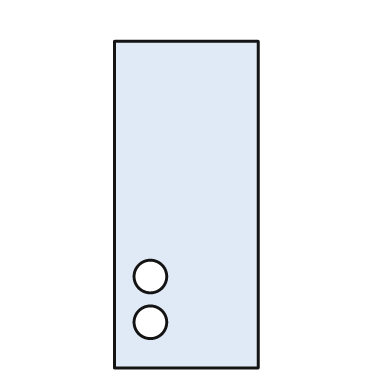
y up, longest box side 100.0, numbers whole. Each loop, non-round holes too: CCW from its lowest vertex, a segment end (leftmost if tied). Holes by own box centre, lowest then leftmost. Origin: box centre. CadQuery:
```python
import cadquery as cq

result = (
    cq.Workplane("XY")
    .moveTo(-22.0, -50.0)
    .lineTo(22.0, -50.0)
    .lineTo(22.0, 50.0)
    .lineTo(-22.0, 50.0)
    .close()
    .moveTo(-11.0, -36.0)
    .circle(5.0)
    .moveTo(-11.0, -22.0)
    .circle(5.0)
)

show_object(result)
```